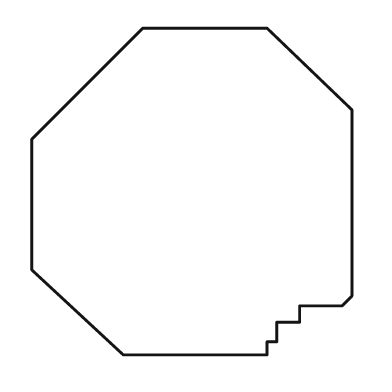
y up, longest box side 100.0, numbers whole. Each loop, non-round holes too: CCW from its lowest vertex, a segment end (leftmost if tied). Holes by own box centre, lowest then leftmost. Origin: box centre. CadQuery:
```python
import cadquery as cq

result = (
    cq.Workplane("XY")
    .moveTo(-21.0, -50.0)
    .lineTo(23.0, -50.0)
    .lineTo(23.0, -46.0)
    .lineTo(26.0, -46.0)
    .lineTo(26.0, -40.0)
    .lineTo(33.0, -40.0)
    .lineTo(33.0, -35.0)
    .lineTo(46.0, -35.0)
    .lineTo(49.0, -32.0)
    .lineTo(49.0, 25.0)
    .lineTo(23.0, 50.0)
    .lineTo(-15.0, 50.0)
    .lineTo(-49.0, 16.0)
    .lineTo(-49.0, -24.0)
    .close()
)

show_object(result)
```